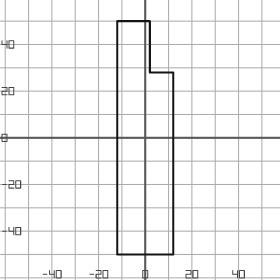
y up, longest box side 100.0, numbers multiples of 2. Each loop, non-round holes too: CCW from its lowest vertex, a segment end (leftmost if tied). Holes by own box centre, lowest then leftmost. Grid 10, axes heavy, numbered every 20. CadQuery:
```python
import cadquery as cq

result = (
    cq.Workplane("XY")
    .moveTo(-12.0, -50.0)
    .lineTo(12.0, -50.0)
    .lineTo(12.0, 28.0)
    .lineTo(2.0, 28.0)
    .lineTo(2.0, 50.0)
    .lineTo(-12.0, 50.0)
    .close()
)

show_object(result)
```